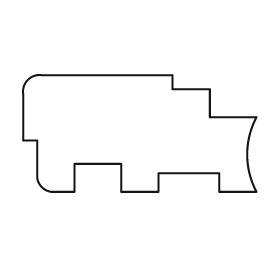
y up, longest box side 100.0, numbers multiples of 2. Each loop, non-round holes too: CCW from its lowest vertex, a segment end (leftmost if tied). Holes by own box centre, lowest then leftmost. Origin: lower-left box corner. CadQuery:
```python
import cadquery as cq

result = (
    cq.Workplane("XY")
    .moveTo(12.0, 0.0)
    .lineTo(22.0, 0.0)
    .lineTo(22.0, 12.0)
    .lineTo(42.0, 12.0)
    .lineTo(42.0, 0.0)
    .lineTo(58.0, 0.0)
    .lineTo(58.0, 8.0)
    .lineTo(84.0, 8.0)
    .lineTo(84.0, 0.0)
    .lineTo(100.0, 0.0)
    .threePointArc((96.0, 16.0), (100.0, 32.0))
    .lineTo(80.0, 32.0)
    .lineTo(80.0, 44.0)
    .lineTo(64.0, 44.0)
    .lineTo(64.0, 50.0)
    .lineTo(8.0, 50.0)
    .threePointArc((2.0, 48.0), (0.0, 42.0))
    .lineTo(0.0, 22.0)
    .lineTo(6.0, 22.0)
    .lineTo(6.0, 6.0)
    .threePointArc((8.0, 2.0), (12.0, 0.0))
    .close()
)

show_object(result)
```